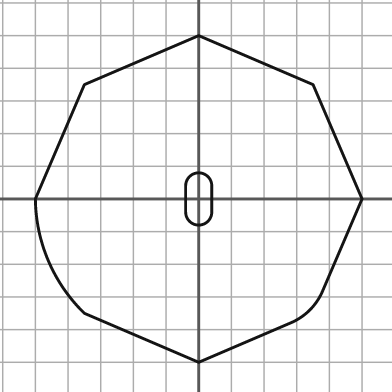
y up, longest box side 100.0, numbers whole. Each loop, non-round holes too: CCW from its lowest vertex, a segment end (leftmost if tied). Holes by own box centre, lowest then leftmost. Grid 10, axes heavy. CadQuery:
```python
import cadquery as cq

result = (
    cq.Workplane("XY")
    .moveTo(0.0, -50.0)
    .lineTo(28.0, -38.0)
    .threePointArc((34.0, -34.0), (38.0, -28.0))
    .lineTo(50.0, 0.0)
    .lineTo(35.0, 35.0)
    .lineTo(0.0, 50.0)
    .lineTo(-35.0, 35.0)
    .lineTo(-50.0, 0.0)
    .threePointArc((-46.0, -19.0), (-35.0, -35.0))
    .close()
    .moveTo(-4.0, -4.0)
    .threePointArc((0.0, -8.0), (4.0, -4.0))
    .lineTo(4.0, 4.0)
    .threePointArc((0.0, 8.0), (-4.0, 4.0))
    .close()
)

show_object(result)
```